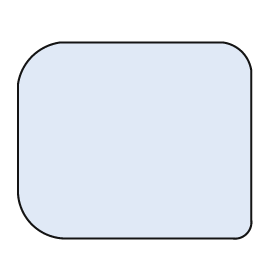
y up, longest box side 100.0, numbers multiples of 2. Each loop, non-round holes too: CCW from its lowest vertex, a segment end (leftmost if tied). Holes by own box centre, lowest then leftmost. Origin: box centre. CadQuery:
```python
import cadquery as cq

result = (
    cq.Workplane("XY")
    .moveTo(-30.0, -42.0)
    .lineTo(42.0, -42.0)
    .threePointArc((48.0, -40.0), (50.0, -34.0))
    .lineTo(50.0, 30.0)
    .threePointArc((46.0, 38.0), (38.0, 42.0))
    .lineTo(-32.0, 42.0)
    .threePointArc((-44.0, 36.0), (-50.0, 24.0))
    .lineTo(-50.0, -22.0)
    .threePointArc((-44.0, -36.0), (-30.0, -42.0))
    .close()
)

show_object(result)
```